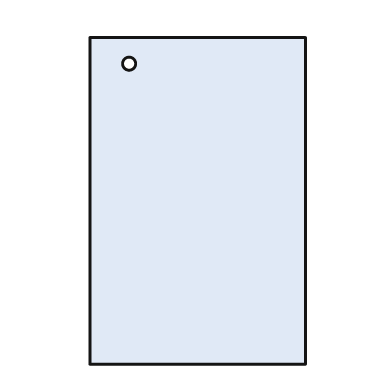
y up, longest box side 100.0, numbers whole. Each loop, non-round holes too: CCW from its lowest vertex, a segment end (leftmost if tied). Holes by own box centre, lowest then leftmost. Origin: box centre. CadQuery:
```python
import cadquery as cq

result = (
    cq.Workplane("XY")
    .moveTo(-33.0, -50.0)
    .lineTo(33.0, -50.0)
    .lineTo(33.0, 50.0)
    .lineTo(-33.0, 50.0)
    .close()
    .moveTo(-21.0, 42.0)
    .circle(2.0)
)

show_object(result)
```